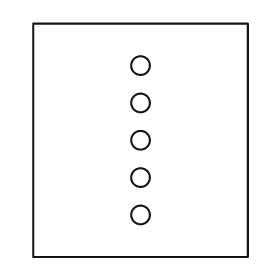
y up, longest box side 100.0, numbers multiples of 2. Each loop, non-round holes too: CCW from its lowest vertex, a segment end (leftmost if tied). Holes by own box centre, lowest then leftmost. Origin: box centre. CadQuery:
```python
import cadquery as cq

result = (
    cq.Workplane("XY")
    .moveTo(-46.0, -50.0)
    .lineTo(46.0, -50.0)
    .lineTo(46.0, 50.0)
    .lineTo(-46.0, 50.0)
    .close()
    .moveTo(0.0, -32.0)
    .circle(4.0)
    .moveTo(0.0, -16.0)
    .circle(4.0)
    .moveTo(0.0, 0.0)
    .circle(4.0)
    .moveTo(0.0, 16.0)
    .circle(4.0)
    .moveTo(0.0, 32.0)
    .circle(4.0)
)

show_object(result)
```